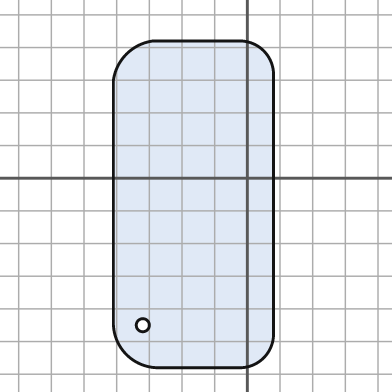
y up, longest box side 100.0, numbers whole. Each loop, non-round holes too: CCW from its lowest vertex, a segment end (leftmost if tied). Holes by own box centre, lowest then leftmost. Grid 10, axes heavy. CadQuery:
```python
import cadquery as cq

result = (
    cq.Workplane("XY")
    .moveTo(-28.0, -58.0)
    .lineTo(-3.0, -58.0)
    .threePointArc((5.0, -55.0), (8.0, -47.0))
    .lineTo(8.0, 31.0)
    .threePointArc((5.0, 39.0), (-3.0, 42.0))
    .lineTo(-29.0, 42.0)
    .threePointArc((-37.0, 38.0), (-41.0, 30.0))
    .lineTo(-41.0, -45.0)
    .threePointArc((-37.0, -54.0), (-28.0, -58.0))
    .close()
    .moveTo(-32.0, -45.0)
    .circle(2.0)
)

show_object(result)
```